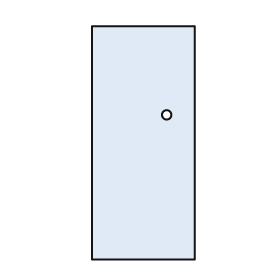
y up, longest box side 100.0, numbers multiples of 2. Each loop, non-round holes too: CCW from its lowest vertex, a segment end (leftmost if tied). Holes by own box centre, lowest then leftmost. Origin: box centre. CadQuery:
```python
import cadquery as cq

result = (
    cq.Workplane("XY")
    .moveTo(-22.0, -50.0)
    .lineTo(22.0, -50.0)
    .lineTo(22.0, 50.0)
    .lineTo(-22.0, 50.0)
    .close()
    .moveTo(10.0, 12.0)
    .circle(2.0)
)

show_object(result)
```